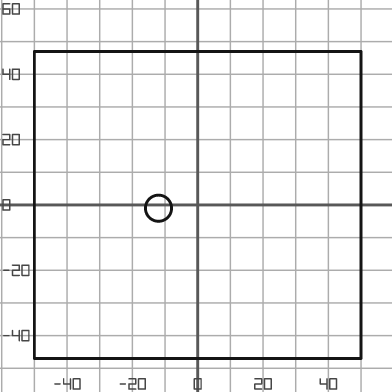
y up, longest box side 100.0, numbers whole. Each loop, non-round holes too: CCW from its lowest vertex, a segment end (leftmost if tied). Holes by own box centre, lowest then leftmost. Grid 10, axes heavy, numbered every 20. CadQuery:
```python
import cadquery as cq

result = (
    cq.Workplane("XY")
    .moveTo(-50.0, -47.0)
    .lineTo(50.0, -47.0)
    .lineTo(50.0, 47.0)
    .lineTo(-50.0, 47.0)
    .close()
    .moveTo(-12.0, -1.0)
    .circle(4.0)
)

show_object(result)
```